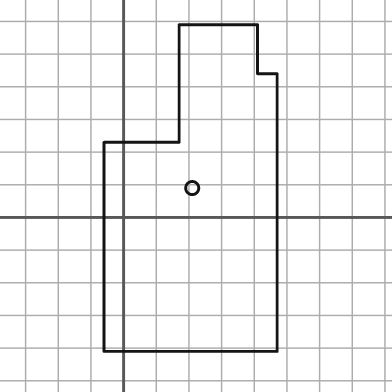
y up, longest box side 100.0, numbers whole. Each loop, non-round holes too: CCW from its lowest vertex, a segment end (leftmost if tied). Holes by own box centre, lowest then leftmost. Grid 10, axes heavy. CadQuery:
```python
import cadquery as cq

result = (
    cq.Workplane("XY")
    .moveTo(-6.0, -41.0)
    .lineTo(47.0, -41.0)
    .lineTo(47.0, 44.0)
    .lineTo(41.0, 44.0)
    .lineTo(41.0, 59.0)
    .lineTo(17.0, 59.0)
    .lineTo(17.0, 23.0)
    .lineTo(-6.0, 23.0)
    .close()
    .moveTo(21.0, 9.0)
    .circle(2.0)
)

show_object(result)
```